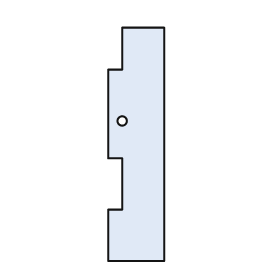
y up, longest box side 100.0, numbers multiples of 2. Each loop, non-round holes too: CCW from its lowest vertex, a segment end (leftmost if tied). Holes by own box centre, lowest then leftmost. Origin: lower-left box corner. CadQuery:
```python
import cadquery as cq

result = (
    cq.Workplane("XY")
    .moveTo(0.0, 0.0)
    .lineTo(24.0, 0.0)
    .lineTo(24.0, 100.0)
    .lineTo(6.0, 100.0)
    .lineTo(6.0, 82.0)
    .lineTo(0.0, 82.0)
    .lineTo(0.0, 44.0)
    .lineTo(6.0, 44.0)
    .lineTo(6.0, 22.0)
    .lineTo(0.0, 22.0)
    .close()
    .moveTo(6.0, 60.0)
    .circle(2.0)
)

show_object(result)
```